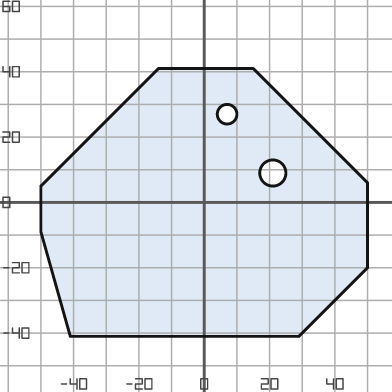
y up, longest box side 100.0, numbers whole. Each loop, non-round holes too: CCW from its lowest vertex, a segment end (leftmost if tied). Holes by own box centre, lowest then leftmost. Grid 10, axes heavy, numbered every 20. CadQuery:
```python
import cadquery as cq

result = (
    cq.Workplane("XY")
    .moveTo(-41.0, -41.0)
    .lineTo(29.0, -41.0)
    .lineTo(50.0, -20.0)
    .lineTo(50.0, 6.0)
    .lineTo(15.0, 41.0)
    .lineTo(-14.0, 41.0)
    .lineTo(-50.0, 5.0)
    .lineTo(-50.0, -9.0)
    .close()
    .moveTo(21.0, 9.0)
    .circle(4.0)
    .moveTo(7.0, 27.0)
    .circle(3.0)
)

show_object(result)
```